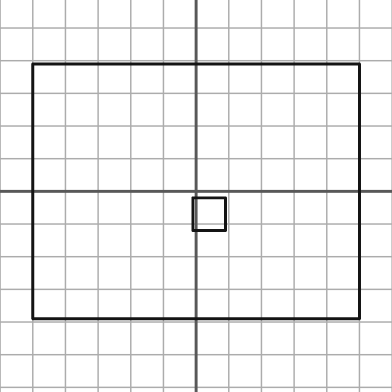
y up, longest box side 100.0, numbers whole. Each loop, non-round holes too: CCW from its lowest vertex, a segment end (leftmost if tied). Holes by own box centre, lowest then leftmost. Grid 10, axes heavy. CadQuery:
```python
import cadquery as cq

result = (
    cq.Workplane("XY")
    .moveTo(-50.0, -39.0)
    .lineTo(50.0, -39.0)
    .lineTo(50.0, 39.0)
    .lineTo(-50.0, 39.0)
    .close()
    .moveTo(-1.0, -12.0)
    .lineTo(9.0, -12.0)
    .lineTo(9.0, -2.0)
    .lineTo(-1.0, -2.0)
    .close()
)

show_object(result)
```